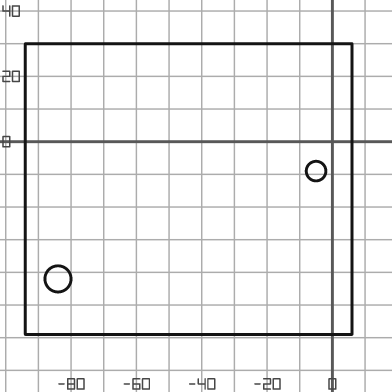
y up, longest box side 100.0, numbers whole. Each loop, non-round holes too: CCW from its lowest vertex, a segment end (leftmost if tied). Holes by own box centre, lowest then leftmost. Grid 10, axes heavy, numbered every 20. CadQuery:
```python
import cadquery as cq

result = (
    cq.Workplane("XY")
    .moveTo(-94.0, -59.0)
    .lineTo(6.0, -59.0)
    .lineTo(6.0, 30.0)
    .lineTo(-94.0, 30.0)
    .close()
    .moveTo(-84.0, -42.0)
    .circle(4.0)
    .moveTo(-5.0, -9.0)
    .circle(3.0)
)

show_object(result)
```